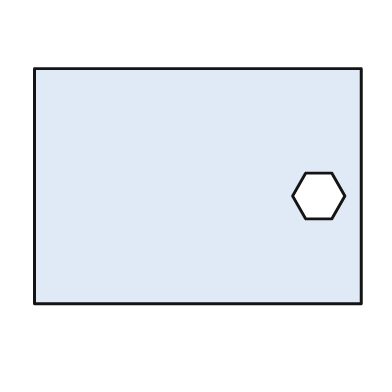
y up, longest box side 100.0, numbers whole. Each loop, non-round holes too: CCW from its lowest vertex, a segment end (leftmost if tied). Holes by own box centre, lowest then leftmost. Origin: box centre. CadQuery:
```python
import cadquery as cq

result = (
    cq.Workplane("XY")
    .moveTo(-50.0, -36.0)
    .lineTo(50.0, -36.0)
    .lineTo(50.0, 36.0)
    .lineTo(-50.0, 36.0)
    .close()
    .moveTo(33.0, -10.0)
    .lineTo(41.0, -10.0)
    .lineTo(45.0, -3.0)
    .lineTo(41.0, 4.0)
    .lineTo(33.0, 4.0)
    .lineTo(29.0, -3.0)
    .close()
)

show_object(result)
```